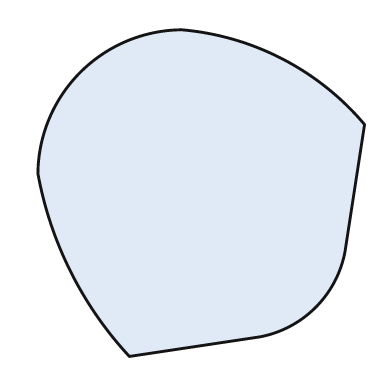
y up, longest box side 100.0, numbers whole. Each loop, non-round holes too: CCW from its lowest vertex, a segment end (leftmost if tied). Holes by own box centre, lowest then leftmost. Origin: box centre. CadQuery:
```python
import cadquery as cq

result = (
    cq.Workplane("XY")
    .moveTo(-22.0, -50.0)
    .lineTo(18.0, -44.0)
    .threePointArc((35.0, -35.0), (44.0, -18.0))
    .lineTo(50.0, 21.0)
    .threePointArc((25.0, 41.0), (-6.0, 50.0))
    .threePointArc((-37.0, 37.0), (-50.0, 6.0))
    .threePointArc((-40.0, -24.0), (-22.0, -50.0))
    .close()
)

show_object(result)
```